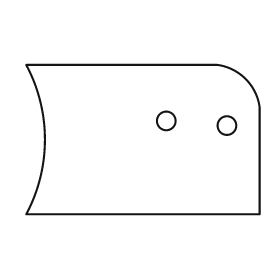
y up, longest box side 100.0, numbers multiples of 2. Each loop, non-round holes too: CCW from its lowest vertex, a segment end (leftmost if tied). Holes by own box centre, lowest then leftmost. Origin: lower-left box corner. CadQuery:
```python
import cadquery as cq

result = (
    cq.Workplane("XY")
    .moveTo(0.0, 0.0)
    .lineTo(100.0, 0.0)
    .lineTo(100.0, 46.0)
    .threePointArc((94.0, 58.0), (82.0, 64.0))
    .lineTo(0.0, 64.0)
    .threePointArc((8.0, 32.0), (0.0, 0.0))
    .close()
    .moveTo(86.0, 38.0)
    .circle(4.0)
    .moveTo(60.0, 40.0)
    .circle(4.0)
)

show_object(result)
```